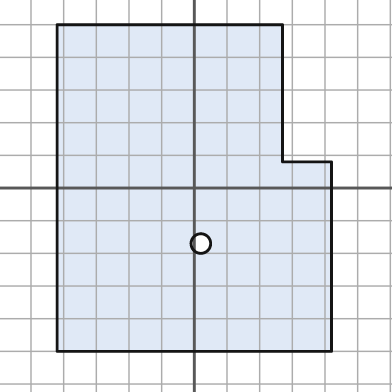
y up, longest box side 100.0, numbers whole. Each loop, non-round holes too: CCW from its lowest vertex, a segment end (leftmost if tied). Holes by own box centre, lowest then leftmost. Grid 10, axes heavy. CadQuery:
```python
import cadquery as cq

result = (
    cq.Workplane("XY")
    .moveTo(-42.0, -50.0)
    .lineTo(42.0, -50.0)
    .lineTo(42.0, 8.0)
    .lineTo(27.0, 8.0)
    .lineTo(27.0, 50.0)
    .lineTo(-42.0, 50.0)
    .close()
    .moveTo(2.0, -17.0)
    .circle(3.0)
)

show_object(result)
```